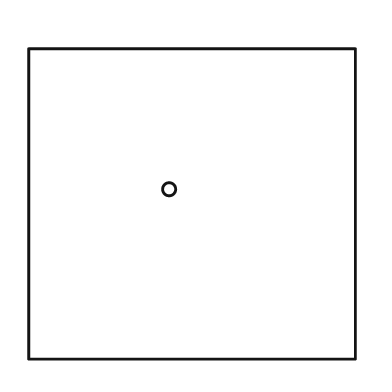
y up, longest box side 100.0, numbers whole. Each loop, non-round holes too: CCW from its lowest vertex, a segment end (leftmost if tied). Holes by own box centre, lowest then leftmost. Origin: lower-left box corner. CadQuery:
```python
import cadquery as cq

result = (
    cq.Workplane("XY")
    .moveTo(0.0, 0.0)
    .lineTo(100.0, 0.0)
    .lineTo(100.0, 95.0)
    .lineTo(0.0, 95.0)
    .close()
    .moveTo(43.0, 52.0)
    .circle(2.0)
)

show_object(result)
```